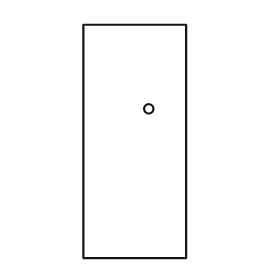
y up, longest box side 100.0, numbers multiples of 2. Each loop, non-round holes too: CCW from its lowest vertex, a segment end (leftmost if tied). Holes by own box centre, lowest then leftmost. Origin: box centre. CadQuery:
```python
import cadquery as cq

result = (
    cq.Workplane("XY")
    .moveTo(-22.0, -50.0)
    .lineTo(22.0, -50.0)
    .lineTo(22.0, 50.0)
    .lineTo(-22.0, 50.0)
    .close()
    .moveTo(6.0, 14.0)
    .circle(2.0)
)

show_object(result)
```